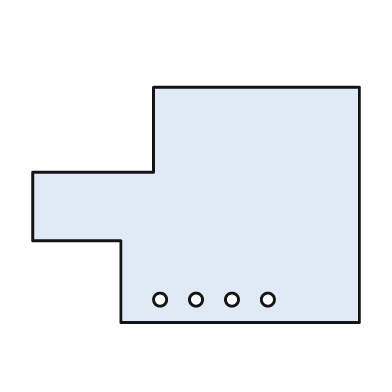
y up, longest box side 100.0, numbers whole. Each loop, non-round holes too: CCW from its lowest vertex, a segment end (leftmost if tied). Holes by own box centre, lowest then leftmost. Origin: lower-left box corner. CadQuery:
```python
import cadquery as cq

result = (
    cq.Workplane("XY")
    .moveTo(27.0, 0.0)
    .lineTo(100.0, 0.0)
    .lineTo(100.0, 72.0)
    .lineTo(37.0, 72.0)
    .lineTo(37.0, 46.0)
    .lineTo(0.0, 46.0)
    .lineTo(0.0, 25.0)
    .lineTo(27.0, 25.0)
    .close()
    .moveTo(39.0, 7.0)
    .circle(2.0)
    .moveTo(50.0, 7.0)
    .circle(2.0)
    .moveTo(61.0, 7.0)
    .circle(2.0)
    .moveTo(72.0, 7.0)
    .circle(2.0)
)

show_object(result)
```